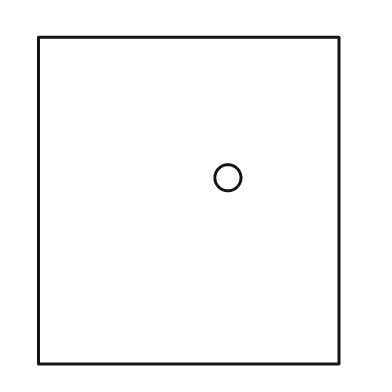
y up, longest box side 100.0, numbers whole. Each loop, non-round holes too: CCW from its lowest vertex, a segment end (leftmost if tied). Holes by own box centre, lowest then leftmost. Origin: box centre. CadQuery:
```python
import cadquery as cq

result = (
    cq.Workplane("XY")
    .moveTo(-46.0, -50.0)
    .lineTo(46.0, -50.0)
    .lineTo(46.0, 50.0)
    .lineTo(-46.0, 50.0)
    .close()
    .moveTo(12.0, 7.0)
    .circle(4.0)
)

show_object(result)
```